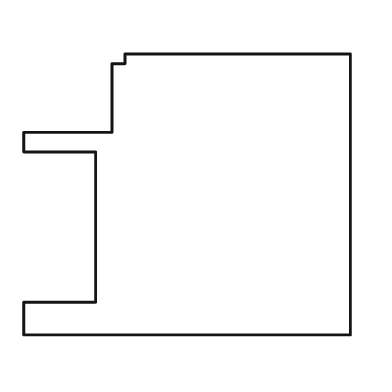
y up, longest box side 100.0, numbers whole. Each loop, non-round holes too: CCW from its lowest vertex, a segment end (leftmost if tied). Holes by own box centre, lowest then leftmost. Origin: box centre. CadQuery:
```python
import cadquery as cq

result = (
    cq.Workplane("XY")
    .moveTo(-50.0, -43.0)
    .lineTo(50.0, -43.0)
    .lineTo(50.0, 43.0)
    .lineTo(-19.0, 43.0)
    .lineTo(-19.0, 40.0)
    .lineTo(-23.0, 40.0)
    .lineTo(-23.0, 19.0)
    .lineTo(-50.0, 19.0)
    .lineTo(-50.0, 13.0)
    .lineTo(-28.0, 13.0)
    .lineTo(-28.0, -33.0)
    .lineTo(-50.0, -33.0)
    .close()
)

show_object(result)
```